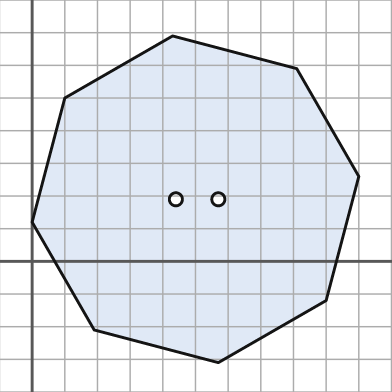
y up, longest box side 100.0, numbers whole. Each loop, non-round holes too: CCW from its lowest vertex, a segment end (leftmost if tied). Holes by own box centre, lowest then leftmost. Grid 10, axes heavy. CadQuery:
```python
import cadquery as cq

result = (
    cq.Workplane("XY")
    .moveTo(57.0, -31.0)
    .lineTo(90.0, -12.0)
    .lineTo(100.0, 26.0)
    .lineTo(81.0, 59.0)
    .lineTo(43.0, 69.0)
    .lineTo(10.0, 50.0)
    .lineTo(0.0, 12.0)
    .lineTo(19.0, -21.0)
    .close()
    .moveTo(44.0, 19.0)
    .circle(2.0)
    .moveTo(57.0, 19.0)
    .circle(2.0)
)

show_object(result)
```